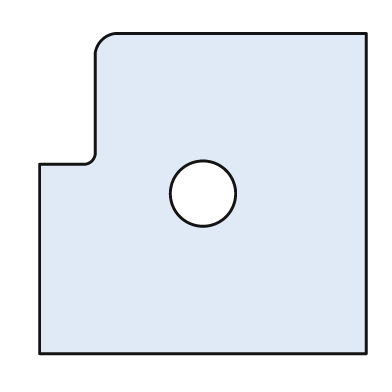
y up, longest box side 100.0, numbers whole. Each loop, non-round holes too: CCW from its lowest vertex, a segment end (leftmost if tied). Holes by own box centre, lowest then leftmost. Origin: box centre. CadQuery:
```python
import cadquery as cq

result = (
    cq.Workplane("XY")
    .moveTo(-50.0, -49.0)
    .lineTo(50.0, -49.0)
    .lineTo(50.0, 49.0)
    .lineTo(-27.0, 49.0)
    .threePointArc((-31.0, 47.0), (-33.0, 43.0))
    .lineTo(-33.0, 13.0)
    .threePointArc((-34.0, 10.0), (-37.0, 9.0))
    .lineTo(-50.0, 9.0)
    .close()
    .moveTo(0.0, 0.0)
    .circle(10.0)
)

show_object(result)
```